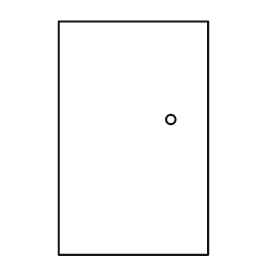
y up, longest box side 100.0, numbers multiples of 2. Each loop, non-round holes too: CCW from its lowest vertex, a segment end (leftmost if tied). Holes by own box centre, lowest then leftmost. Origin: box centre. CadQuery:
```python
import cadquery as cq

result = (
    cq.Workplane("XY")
    .moveTo(-32.0, -50.0)
    .lineTo(32.0, -50.0)
    .lineTo(32.0, 50.0)
    .lineTo(-32.0, 50.0)
    .close()
    .moveTo(16.0, 8.0)
    .circle(2.0)
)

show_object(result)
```